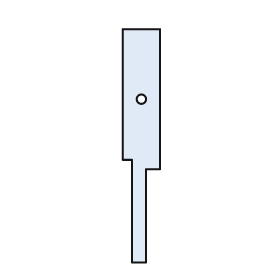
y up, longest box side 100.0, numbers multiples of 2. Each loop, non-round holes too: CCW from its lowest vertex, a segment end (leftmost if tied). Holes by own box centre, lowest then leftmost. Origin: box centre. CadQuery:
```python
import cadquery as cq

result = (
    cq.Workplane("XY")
    .moveTo(-4.0, -50.0)
    .lineTo(2.0, -50.0)
    .lineTo(2.0, -10.0)
    .lineTo(8.0, -10.0)
    .lineTo(8.0, 50.0)
    .lineTo(-8.0, 50.0)
    .lineTo(-8.0, -6.0)
    .lineTo(-4.0, -6.0)
    .close()
    .moveTo(0.0, 20.0)
    .circle(2.0)
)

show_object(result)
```